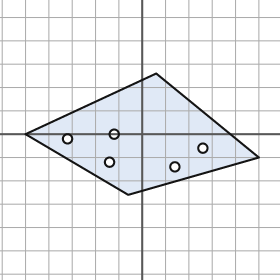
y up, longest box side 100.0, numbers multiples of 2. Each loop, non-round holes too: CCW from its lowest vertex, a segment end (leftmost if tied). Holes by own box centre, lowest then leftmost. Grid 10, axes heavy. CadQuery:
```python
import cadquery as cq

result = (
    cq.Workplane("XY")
    .moveTo(-6.0, -26.0)
    .lineTo(50.0, -10.0)
    .lineTo(6.0, 26.0)
    .lineTo(-50.0, 0.0)
    .close()
    .moveTo(14.0, -14.0)
    .circle(2.0)
    .moveTo(-14.0, -12.0)
    .circle(2.0)
    .moveTo(26.0, -6.0)
    .circle(2.0)
    .moveTo(-32.0, -2.0)
    .circle(2.0)
    .moveTo(-12.0, 0.0)
    .circle(2.0)
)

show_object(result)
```